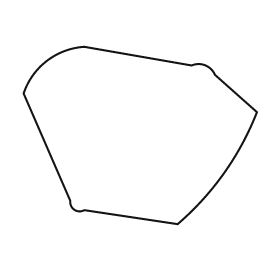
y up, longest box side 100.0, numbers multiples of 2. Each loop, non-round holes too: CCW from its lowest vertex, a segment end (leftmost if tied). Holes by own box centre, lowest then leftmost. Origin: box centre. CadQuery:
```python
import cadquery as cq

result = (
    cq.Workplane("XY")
    .moveTo(16.0, -38.0)
    .threePointArc((36.0, -16.0), (50.0, 10.0))
    .lineTo(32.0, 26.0)
    .threePointArc((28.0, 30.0), (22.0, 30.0))
    .lineTo(-24.0, 38.0)
    .threePointArc((-40.0, 32.0), (-50.0, 18.0))
    .lineTo(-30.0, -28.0)
    .threePointArc((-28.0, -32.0), (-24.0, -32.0))
    .close()
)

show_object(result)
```